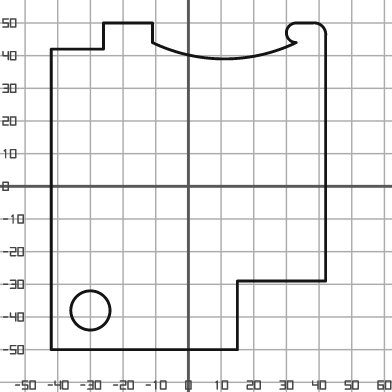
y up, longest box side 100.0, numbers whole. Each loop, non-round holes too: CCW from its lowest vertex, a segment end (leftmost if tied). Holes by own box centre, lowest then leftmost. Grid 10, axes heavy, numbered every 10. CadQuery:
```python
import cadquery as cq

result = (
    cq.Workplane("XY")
    .moveTo(-42.0, -50.0)
    .lineTo(15.0, -50.0)
    .lineTo(15.0, -29.0)
    .lineTo(42.0, -29.0)
    .lineTo(42.0, 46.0)
    .threePointArc((41.0, 49.0), (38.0, 50.0))
    .lineTo(33.0, 50.0)
    .threePointArc((30.0, 47.0), (33.0, 44.0))
    .threePointArc((11.0, 39.0), (-11.0, 44.0))
    .lineTo(-11.0, 50.0)
    .lineTo(-26.0, 50.0)
    .lineTo(-26.0, 42.0)
    .lineTo(-42.0, 42.0)
    .close()
    .moveTo(-30.0, -38.0)
    .circle(6.0)
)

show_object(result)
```